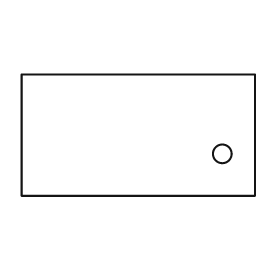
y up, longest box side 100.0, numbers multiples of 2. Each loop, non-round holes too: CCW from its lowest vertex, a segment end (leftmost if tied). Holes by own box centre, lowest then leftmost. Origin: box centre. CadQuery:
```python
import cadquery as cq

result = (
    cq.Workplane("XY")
    .moveTo(-50.0, -26.0)
    .lineTo(50.0, -26.0)
    .lineTo(50.0, 26.0)
    .lineTo(-50.0, 26.0)
    .close()
    .moveTo(36.0, -8.0)
    .circle(4.0)
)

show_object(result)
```